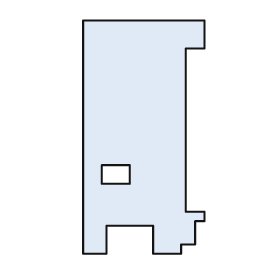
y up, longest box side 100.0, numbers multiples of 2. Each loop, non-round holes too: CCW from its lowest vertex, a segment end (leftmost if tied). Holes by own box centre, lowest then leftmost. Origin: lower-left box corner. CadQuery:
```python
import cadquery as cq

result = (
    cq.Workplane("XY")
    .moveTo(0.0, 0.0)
    .lineTo(10.0, 0.0)
    .lineTo(10.0, 12.0)
    .lineTo(30.0, 12.0)
    .lineTo(30.0, 0.0)
    .lineTo(42.0, 0.0)
    .lineTo(42.0, 4.0)
    .lineTo(48.0, 4.0)
    .lineTo(48.0, 14.0)
    .lineTo(52.0, 14.0)
    .lineTo(52.0, 18.0)
    .lineTo(44.0, 18.0)
    .lineTo(44.0, 88.0)
    .lineTo(52.0, 88.0)
    .lineTo(52.0, 100.0)
    .lineTo(0.0, 100.0)
    .close()
    .moveTo(8.0, 30.0)
    .lineTo(20.0, 30.0)
    .lineTo(20.0, 38.0)
    .lineTo(8.0, 38.0)
    .close()
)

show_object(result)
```